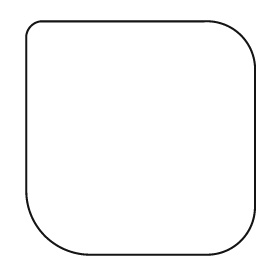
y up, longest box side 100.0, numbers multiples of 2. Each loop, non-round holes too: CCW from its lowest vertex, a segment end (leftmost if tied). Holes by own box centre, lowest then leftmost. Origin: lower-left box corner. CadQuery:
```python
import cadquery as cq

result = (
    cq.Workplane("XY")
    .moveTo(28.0, 0.0)
    .lineTo(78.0, 0.0)
    .threePointArc((92.0, 6.0), (98.0, 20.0))
    .lineTo(98.0, 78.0)
    .threePointArc((92.0, 94.0), (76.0, 100.0))
    .lineTo(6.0, 100.0)
    .threePointArc((2.0, 98.0), (0.0, 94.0))
    .lineTo(0.0, 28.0)
    .threePointArc((8.0, 8.0), (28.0, 0.0))
    .close()
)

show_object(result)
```